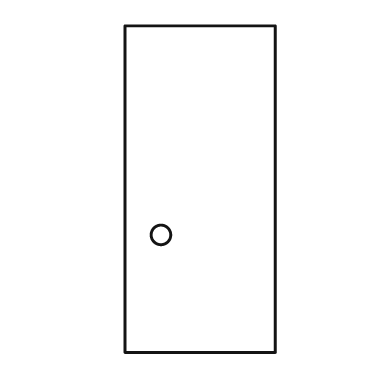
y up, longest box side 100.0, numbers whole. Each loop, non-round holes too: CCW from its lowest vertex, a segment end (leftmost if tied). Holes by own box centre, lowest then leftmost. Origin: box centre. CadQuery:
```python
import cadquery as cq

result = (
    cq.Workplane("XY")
    .moveTo(-23.0, -50.0)
    .lineTo(23.0, -50.0)
    .lineTo(23.0, 50.0)
    .lineTo(-23.0, 50.0)
    .close()
    .moveTo(-12.0, -14.0)
    .circle(3.0)
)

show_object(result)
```